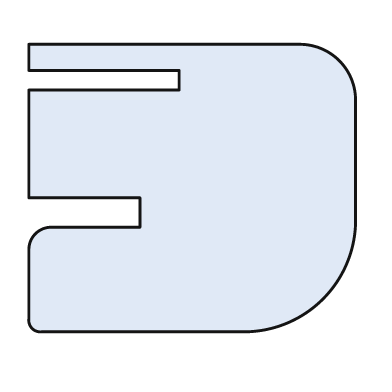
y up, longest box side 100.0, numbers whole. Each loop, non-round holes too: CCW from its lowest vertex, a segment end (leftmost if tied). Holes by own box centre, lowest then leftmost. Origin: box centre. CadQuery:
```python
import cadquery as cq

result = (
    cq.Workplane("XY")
    .moveTo(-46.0, -44.0)
    .lineTo(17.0, -44.0)
    .threePointArc((40.0, -34.0), (50.0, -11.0))
    .lineTo(50.0, 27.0)
    .threePointArc((45.0, 39.0), (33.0, 44.0))
    .lineTo(-50.0, 44.0)
    .lineTo(-50.0, 36.0)
    .lineTo(-4.0, 36.0)
    .lineTo(-4.0, 30.0)
    .lineTo(-50.0, 30.0)
    .lineTo(-50.0, -3.0)
    .lineTo(-16.0, -3.0)
    .lineTo(-16.0, -12.0)
    .lineTo(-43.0, -12.0)
    .threePointArc((-48.0, -14.0), (-50.0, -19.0))
    .lineTo(-50.0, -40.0)
    .threePointArc((-49.0, -43.0), (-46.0, -44.0))
    .close()
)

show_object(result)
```